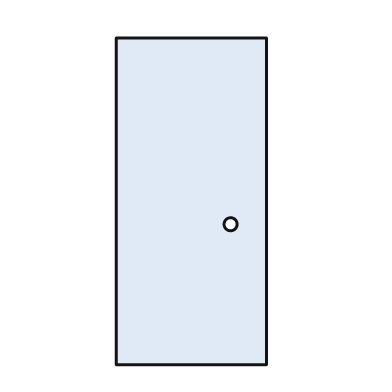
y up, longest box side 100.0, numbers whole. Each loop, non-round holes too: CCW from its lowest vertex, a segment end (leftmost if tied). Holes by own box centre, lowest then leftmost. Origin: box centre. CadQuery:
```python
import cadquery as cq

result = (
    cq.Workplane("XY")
    .moveTo(-23.0, -50.0)
    .lineTo(23.0, -50.0)
    .lineTo(23.0, 50.0)
    .lineTo(-23.0, 50.0)
    .close()
    .moveTo(12.0, -7.0)
    .circle(2.0)
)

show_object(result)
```